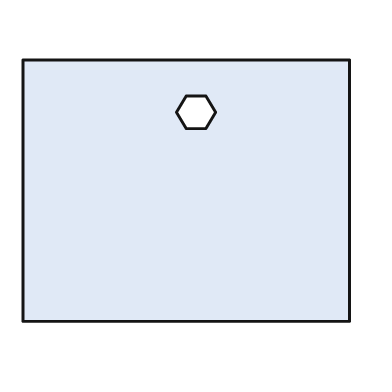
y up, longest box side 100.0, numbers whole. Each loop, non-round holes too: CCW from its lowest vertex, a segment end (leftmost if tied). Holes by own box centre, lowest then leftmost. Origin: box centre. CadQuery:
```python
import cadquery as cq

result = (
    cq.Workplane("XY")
    .moveTo(-50.0, -40.0)
    .lineTo(50.0, -40.0)
    .lineTo(50.0, 40.0)
    .lineTo(-50.0, 40.0)
    .close()
    .moveTo(0.0, 19.0)
    .lineTo(6.0, 19.0)
    .lineTo(9.0, 24.0)
    .lineTo(6.0, 29.0)
    .lineTo(0.0, 29.0)
    .lineTo(-3.0, 24.0)
    .close()
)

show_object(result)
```